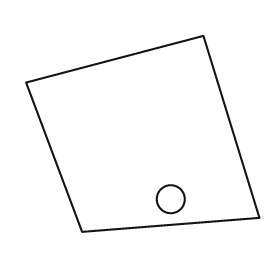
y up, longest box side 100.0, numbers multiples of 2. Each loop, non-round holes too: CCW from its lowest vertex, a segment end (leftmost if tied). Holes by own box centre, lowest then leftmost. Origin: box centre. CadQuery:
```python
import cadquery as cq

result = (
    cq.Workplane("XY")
    .moveTo(-26.0, -42.0)
    .lineTo(50.0, -36.0)
    .lineTo(26.0, 42.0)
    .lineTo(-50.0, 22.0)
    .close()
    .moveTo(12.0, -28.0)
    .circle(6.0)
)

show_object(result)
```